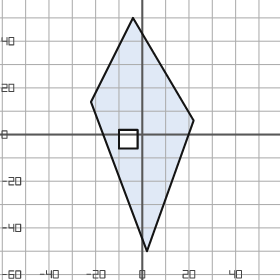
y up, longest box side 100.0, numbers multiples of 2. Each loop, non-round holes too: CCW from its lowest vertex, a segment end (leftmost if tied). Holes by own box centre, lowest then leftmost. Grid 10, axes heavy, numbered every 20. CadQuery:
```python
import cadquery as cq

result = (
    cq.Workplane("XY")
    .moveTo(2.0, -50.0)
    .lineTo(22.0, 6.0)
    .lineTo(-4.0, 50.0)
    .lineTo(-22.0, 14.0)
    .close()
    .moveTo(-10.0, -6.0)
    .lineTo(-2.0, -6.0)
    .lineTo(-2.0, 2.0)
    .lineTo(-10.0, 2.0)
    .close()
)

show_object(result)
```